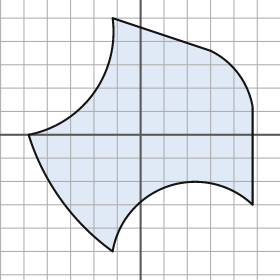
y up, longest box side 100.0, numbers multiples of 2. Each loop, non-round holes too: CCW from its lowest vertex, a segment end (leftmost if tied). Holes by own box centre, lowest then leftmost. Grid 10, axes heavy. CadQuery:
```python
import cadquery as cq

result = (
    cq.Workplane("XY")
    .moveTo(-12.0, -50.0)
    .threePointArc((12.0, -22.0), (48.0, -30.0))
    .lineTo(48.0, 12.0)
    .threePointArc((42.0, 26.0), (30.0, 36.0))
    .lineTo(-12.0, 50.0)
    .threePointArc((-20.0, 18.0), (-48.0, 0.0))
    .threePointArc((-34.0, -28.0), (-12.0, -50.0))
    .close()
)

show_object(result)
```